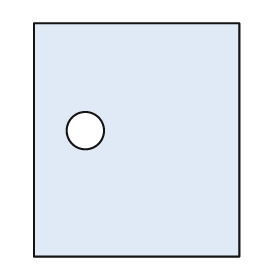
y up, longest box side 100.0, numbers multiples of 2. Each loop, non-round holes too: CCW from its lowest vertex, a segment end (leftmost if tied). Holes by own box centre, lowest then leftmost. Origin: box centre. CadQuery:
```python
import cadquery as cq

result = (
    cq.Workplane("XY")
    .moveTo(-44.0, -50.0)
    .lineTo(44.0, -50.0)
    .lineTo(44.0, 50.0)
    .lineTo(-44.0, 50.0)
    .close()
    .moveTo(-22.0, 4.0)
    .circle(8.0)
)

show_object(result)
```